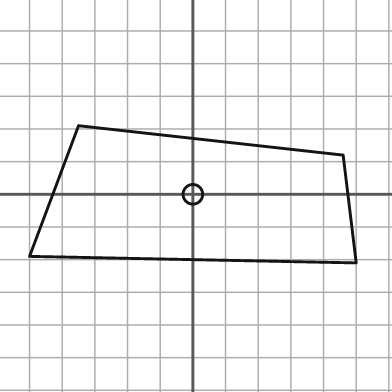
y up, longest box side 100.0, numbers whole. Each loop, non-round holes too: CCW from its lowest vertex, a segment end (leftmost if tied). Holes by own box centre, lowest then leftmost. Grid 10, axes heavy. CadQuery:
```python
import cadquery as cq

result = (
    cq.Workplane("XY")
    .moveTo(50.0, -21.0)
    .lineTo(46.0, 12.0)
    .lineTo(-35.0, 21.0)
    .lineTo(-50.0, -19.0)
    .close()
    .moveTo(0.0, 0.0)
    .circle(3.0)
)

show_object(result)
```